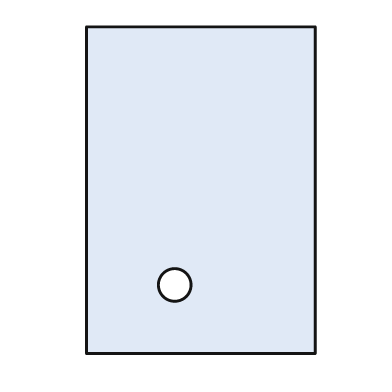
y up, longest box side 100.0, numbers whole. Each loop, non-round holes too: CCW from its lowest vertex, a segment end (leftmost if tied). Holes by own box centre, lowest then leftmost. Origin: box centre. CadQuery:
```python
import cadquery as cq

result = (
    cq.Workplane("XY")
    .moveTo(-35.0, -50.0)
    .lineTo(35.0, -50.0)
    .lineTo(35.0, 50.0)
    .lineTo(-35.0, 50.0)
    .close()
    .moveTo(-8.0, -29.0)
    .circle(5.0)
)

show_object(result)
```